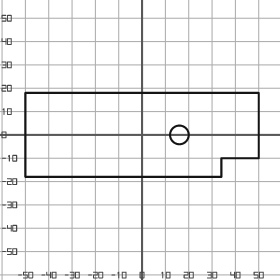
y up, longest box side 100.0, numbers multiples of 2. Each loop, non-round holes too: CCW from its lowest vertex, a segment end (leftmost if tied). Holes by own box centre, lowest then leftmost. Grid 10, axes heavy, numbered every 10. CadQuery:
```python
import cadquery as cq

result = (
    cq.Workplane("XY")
    .moveTo(-50.0, -18.0)
    .lineTo(34.0, -18.0)
    .lineTo(34.0, -10.0)
    .lineTo(50.0, -10.0)
    .lineTo(50.0, 18.0)
    .lineTo(-50.0, 18.0)
    .close()
    .moveTo(16.0, 0.0)
    .circle(4.0)
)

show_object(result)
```